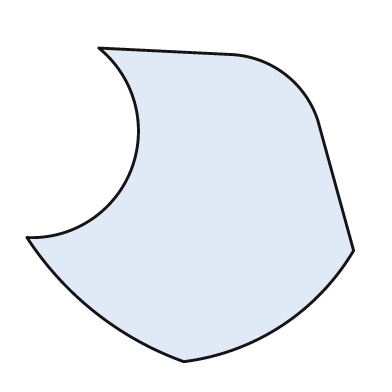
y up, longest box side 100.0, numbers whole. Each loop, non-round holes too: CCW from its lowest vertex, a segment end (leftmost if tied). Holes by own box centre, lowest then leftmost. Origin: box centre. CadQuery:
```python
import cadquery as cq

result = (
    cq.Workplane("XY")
    .moveTo(-2.0, -48.0)
    .threePointArc((28.0, -37.0), (50.0, -14.0))
    .lineTo(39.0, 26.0)
    .threePointArc((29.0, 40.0), (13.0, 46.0))
    .lineTo(-28.0, 48.0)
    .threePointArc((-18.0, 11.0), (-50.0, -10.0))
    .threePointArc((-29.0, -33.0), (-2.0, -48.0))
    .close()
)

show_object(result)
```